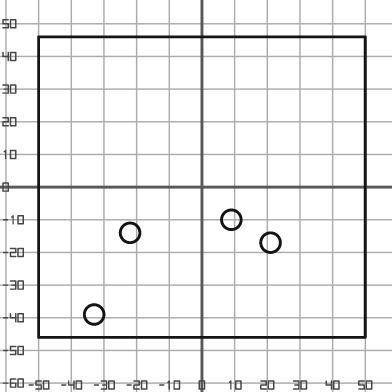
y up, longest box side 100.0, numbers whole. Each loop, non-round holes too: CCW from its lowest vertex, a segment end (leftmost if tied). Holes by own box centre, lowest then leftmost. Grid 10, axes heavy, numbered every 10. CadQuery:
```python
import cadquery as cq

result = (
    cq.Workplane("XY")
    .moveTo(-50.0, -46.0)
    .lineTo(50.0, -46.0)
    .lineTo(50.0, 46.0)
    .lineTo(-50.0, 46.0)
    .close()
    .moveTo(-33.0, -39.0)
    .circle(3.0)
    .moveTo(21.0, -17.0)
    .circle(3.0)
    .moveTo(-22.0, -14.0)
    .circle(3.0)
    .moveTo(9.0, -10.0)
    .circle(3.0)
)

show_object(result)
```